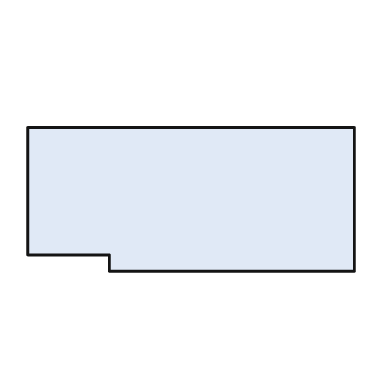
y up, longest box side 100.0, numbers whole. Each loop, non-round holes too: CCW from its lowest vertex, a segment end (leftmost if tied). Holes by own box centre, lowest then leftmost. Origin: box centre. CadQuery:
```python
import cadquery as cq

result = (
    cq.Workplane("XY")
    .moveTo(-25.0, -22.0)
    .lineTo(50.0, -22.0)
    .lineTo(50.0, 22.0)
    .lineTo(-50.0, 22.0)
    .lineTo(-50.0, -17.0)
    .lineTo(-25.0, -17.0)
    .close()
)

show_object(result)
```